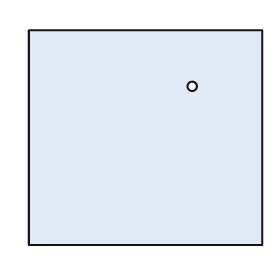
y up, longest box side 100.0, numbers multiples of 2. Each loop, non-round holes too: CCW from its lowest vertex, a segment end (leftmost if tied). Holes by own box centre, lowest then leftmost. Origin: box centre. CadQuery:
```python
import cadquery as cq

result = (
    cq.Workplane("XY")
    .moveTo(-50.0, -46.0)
    .lineTo(50.0, -46.0)
    .lineTo(50.0, 46.0)
    .lineTo(-50.0, 46.0)
    .close()
    .moveTo(20.0, 22.0)
    .circle(2.0)
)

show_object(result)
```